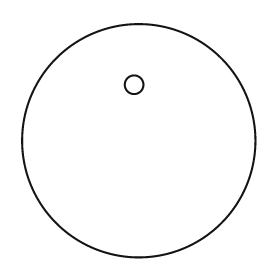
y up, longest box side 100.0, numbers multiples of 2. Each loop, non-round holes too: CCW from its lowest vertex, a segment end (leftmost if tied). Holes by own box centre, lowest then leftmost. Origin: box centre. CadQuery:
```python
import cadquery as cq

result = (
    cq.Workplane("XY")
    .moveTo(0.0, 0.0)
    .circle(50.0)
    .moveTo(-2.0, 24.0)
    .circle(4.0)
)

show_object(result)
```